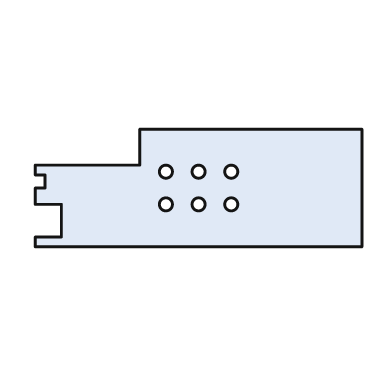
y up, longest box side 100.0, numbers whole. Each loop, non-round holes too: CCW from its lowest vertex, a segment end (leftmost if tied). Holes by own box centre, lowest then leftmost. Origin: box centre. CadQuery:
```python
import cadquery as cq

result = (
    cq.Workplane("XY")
    .moveTo(-50.0, -18.0)
    .lineTo(50.0, -18.0)
    .lineTo(50.0, 18.0)
    .lineTo(-18.0, 18.0)
    .lineTo(-18.0, 7.0)
    .lineTo(-50.0, 7.0)
    .lineTo(-50.0, 4.0)
    .lineTo(-47.0, 4.0)
    .lineTo(-47.0, 0.0)
    .lineTo(-50.0, 0.0)
    .lineTo(-50.0, -5.0)
    .lineTo(-42.0, -5.0)
    .lineTo(-42.0, -15.0)
    .lineTo(-50.0, -15.0)
    .close()
    .moveTo(-10.0, -5.0)
    .circle(2.0)
    .moveTo(0.0, -5.0)
    .circle(2.0)
    .moveTo(10.0, -5.0)
    .circle(2.0)
    .moveTo(-10.0, 5.0)
    .circle(2.0)
    .moveTo(0.0, 5.0)
    .circle(2.0)
    .moveTo(10.0, 5.0)
    .circle(2.0)
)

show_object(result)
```